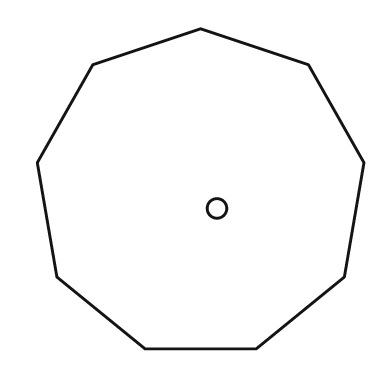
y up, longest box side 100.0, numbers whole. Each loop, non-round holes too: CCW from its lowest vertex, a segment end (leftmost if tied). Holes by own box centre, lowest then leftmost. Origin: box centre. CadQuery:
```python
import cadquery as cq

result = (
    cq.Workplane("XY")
    .moveTo(-17.0, -49.0)
    .lineTo(17.0, -49.0)
    .lineTo(44.0, -27.0)
    .lineTo(50.0, 8.0)
    .lineTo(33.0, 38.0)
    .lineTo(0.0, 49.0)
    .lineTo(-33.0, 38.0)
    .lineTo(-50.0, 8.0)
    .lineTo(-44.0, -27.0)
    .close()
    .moveTo(5.0, -6.0)
    .circle(3.0)
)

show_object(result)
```